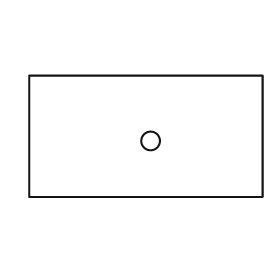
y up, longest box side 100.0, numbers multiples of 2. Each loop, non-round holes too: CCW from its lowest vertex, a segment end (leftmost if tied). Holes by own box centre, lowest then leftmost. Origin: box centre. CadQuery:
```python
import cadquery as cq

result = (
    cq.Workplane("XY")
    .moveTo(-50.0, -26.0)
    .lineTo(50.0, -26.0)
    .lineTo(50.0, 26.0)
    .lineTo(-50.0, 26.0)
    .close()
    .moveTo(2.0, -2.0)
    .circle(4.0)
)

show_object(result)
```